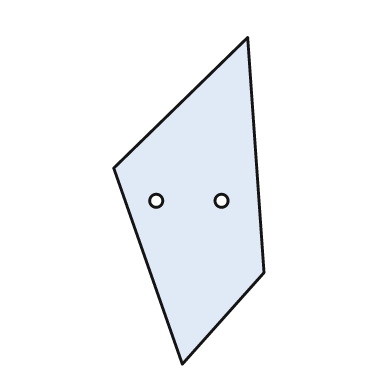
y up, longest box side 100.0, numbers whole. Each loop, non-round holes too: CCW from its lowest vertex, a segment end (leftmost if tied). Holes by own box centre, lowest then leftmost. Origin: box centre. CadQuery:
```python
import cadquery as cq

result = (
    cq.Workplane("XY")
    .moveTo(-2.0, -50.0)
    .lineTo(23.0, -22.0)
    .lineTo(18.0, 50.0)
    .lineTo(-23.0, 10.0)
    .close()
    .moveTo(-10.0, 0.0)
    .circle(2.0)
    .moveTo(10.0, 0.0)
    .circle(2.0)
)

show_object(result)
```